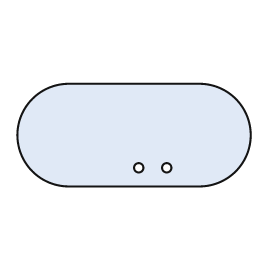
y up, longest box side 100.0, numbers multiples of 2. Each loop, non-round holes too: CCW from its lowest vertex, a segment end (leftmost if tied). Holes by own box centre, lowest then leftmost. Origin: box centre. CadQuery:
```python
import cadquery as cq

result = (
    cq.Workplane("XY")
    .moveTo(-28.0, -22.0)
    .lineTo(28.0, -22.0)
    .threePointArc((50.0, 0.0), (28.0, 22.0))
    .lineTo(-28.0, 22.0)
    .threePointArc((-50.0, 0.0), (-28.0, -22.0))
    .close()
    .moveTo(2.0, -14.0)
    .circle(2.0)
    .moveTo(14.0, -14.0)
    .circle(2.0)
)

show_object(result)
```